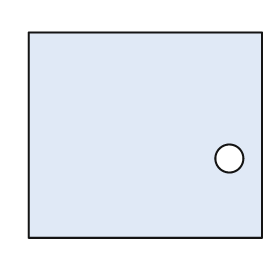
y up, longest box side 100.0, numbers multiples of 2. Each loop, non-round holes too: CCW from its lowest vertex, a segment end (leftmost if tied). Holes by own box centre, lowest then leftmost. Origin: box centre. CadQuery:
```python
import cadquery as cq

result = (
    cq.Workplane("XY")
    .moveTo(-50.0, -44.0)
    .lineTo(50.0, -44.0)
    .lineTo(50.0, 44.0)
    .lineTo(-50.0, 44.0)
    .close()
    .moveTo(36.0, -10.0)
    .circle(6.0)
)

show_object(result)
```